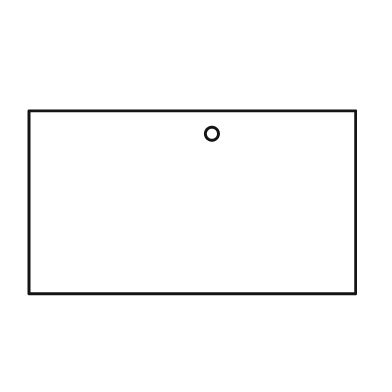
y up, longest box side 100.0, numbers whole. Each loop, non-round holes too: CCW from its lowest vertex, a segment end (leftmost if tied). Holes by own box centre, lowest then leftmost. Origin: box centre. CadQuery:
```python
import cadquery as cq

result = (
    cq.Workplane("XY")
    .moveTo(-50.0, -28.0)
    .lineTo(50.0, -28.0)
    .lineTo(50.0, 28.0)
    .lineTo(-50.0, 28.0)
    .close()
    .moveTo(6.0, 21.0)
    .circle(2.0)
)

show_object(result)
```